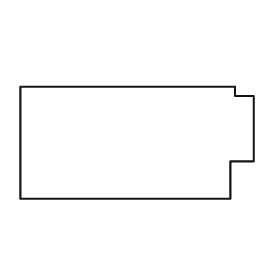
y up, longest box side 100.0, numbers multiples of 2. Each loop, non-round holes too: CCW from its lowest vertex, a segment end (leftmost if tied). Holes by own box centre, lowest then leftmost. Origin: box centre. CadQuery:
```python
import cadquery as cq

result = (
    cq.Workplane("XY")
    .moveTo(-50.0, -24.0)
    .lineTo(40.0, -24.0)
    .lineTo(40.0, -8.0)
    .lineTo(50.0, -8.0)
    .lineTo(50.0, 20.0)
    .lineTo(42.0, 20.0)
    .lineTo(42.0, 24.0)
    .lineTo(-50.0, 24.0)
    .close()
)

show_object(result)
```